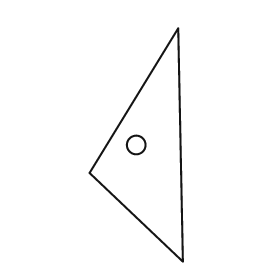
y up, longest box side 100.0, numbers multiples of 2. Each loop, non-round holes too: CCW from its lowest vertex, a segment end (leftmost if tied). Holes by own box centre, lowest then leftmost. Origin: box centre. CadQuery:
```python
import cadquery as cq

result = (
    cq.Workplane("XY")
    .moveTo(20.0, -50.0)
    .lineTo(18.0, 50.0)
    .lineTo(-20.0, -12.0)
    .close()
    .moveTo(0.0, 0.0)
    .circle(4.0)
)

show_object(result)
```